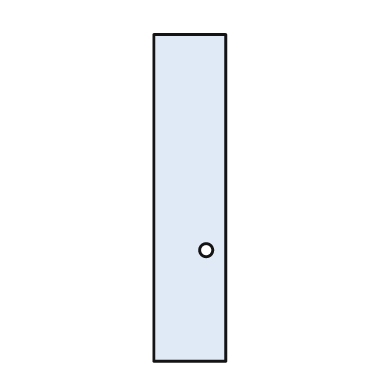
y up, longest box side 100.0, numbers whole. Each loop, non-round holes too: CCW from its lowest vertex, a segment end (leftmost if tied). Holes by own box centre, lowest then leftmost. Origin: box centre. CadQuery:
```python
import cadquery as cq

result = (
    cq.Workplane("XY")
    .moveTo(-11.0, -50.0)
    .lineTo(11.0, -50.0)
    .lineTo(11.0, 50.0)
    .lineTo(-11.0, 50.0)
    .close()
    .moveTo(5.0, -16.0)
    .circle(2.0)
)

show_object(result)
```